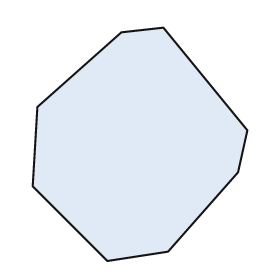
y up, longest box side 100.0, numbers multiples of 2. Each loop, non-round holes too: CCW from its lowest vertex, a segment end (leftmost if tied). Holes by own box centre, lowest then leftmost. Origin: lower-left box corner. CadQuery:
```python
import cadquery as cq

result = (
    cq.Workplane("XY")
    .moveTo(32.0, 0.0)
    .lineTo(58.0, 4.0)
    .lineTo(88.0, 38.0)
    .lineTo(92.0, 56.0)
    .lineTo(56.0, 100.0)
    .lineTo(38.0, 98.0)
    .lineTo(2.0, 66.0)
    .lineTo(0.0, 32.0)
    .close()
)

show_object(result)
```